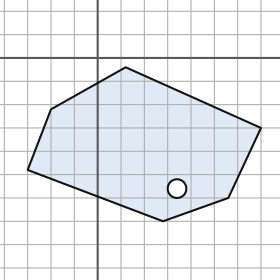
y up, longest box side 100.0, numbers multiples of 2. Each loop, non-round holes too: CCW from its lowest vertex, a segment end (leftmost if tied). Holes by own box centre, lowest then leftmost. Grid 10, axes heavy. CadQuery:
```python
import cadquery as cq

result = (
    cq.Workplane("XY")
    .moveTo(28.0, -70.0)
    .lineTo(56.0, -60.0)
    .lineTo(70.0, -30.0)
    .lineTo(12.0, -4.0)
    .lineTo(-20.0, -22.0)
    .lineTo(-30.0, -48.0)
    .close()
    .moveTo(34.0, -56.0)
    .circle(4.0)
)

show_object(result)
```